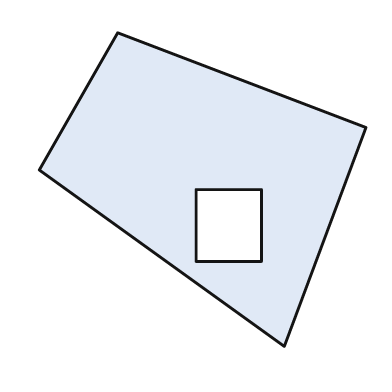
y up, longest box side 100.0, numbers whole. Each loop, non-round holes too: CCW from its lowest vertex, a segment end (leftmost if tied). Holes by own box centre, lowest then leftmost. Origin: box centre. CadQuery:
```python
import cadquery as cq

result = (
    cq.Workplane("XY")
    .moveTo(25.0, -48.0)
    .lineTo(50.0, 19.0)
    .lineTo(-26.0, 48.0)
    .lineTo(-50.0, 6.0)
    .close()
    .moveTo(-2.0, -22.0)
    .lineTo(18.0, -22.0)
    .lineTo(18.0, 0.0)
    .lineTo(-2.0, 0.0)
    .close()
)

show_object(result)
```